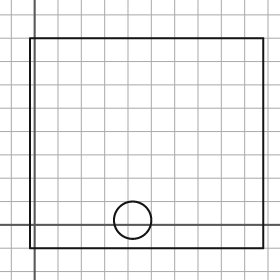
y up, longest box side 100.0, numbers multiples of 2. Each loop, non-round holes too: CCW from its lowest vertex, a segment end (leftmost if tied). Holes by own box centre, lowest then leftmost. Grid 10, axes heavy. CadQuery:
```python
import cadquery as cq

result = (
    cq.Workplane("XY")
    .moveTo(-2.0, -10.0)
    .lineTo(98.0, -10.0)
    .lineTo(98.0, 80.0)
    .lineTo(-2.0, 80.0)
    .close()
    .moveTo(42.0, 2.0)
    .circle(8.0)
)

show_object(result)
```